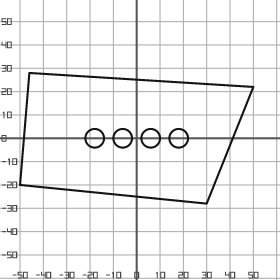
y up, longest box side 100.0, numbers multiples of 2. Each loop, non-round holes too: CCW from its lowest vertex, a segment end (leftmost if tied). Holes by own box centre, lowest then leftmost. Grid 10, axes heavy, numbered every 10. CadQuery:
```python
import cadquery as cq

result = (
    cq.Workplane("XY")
    .moveTo(30.0, -28.0)
    .lineTo(50.0, 22.0)
    .lineTo(-46.0, 28.0)
    .lineTo(-50.0, -20.0)
    .close()
    .moveTo(-18.0, 0.0)
    .circle(4.0)
    .moveTo(-6.0, 0.0)
    .circle(4.0)
    .moveTo(6.0, 0.0)
    .circle(4.0)
    .moveTo(18.0, 0.0)
    .circle(4.0)
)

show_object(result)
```